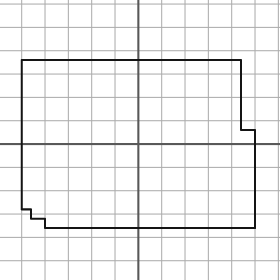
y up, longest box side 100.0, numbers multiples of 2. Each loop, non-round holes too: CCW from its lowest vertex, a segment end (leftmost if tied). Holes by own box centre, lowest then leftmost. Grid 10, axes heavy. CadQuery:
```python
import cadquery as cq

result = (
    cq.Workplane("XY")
    .moveTo(-40.0, -36.0)
    .lineTo(50.0, -36.0)
    .lineTo(50.0, 6.0)
    .lineTo(44.0, 6.0)
    .lineTo(44.0, 36.0)
    .lineTo(-50.0, 36.0)
    .lineTo(-50.0, -28.0)
    .lineTo(-46.0, -28.0)
    .lineTo(-46.0, -32.0)
    .lineTo(-40.0, -32.0)
    .close()
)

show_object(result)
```